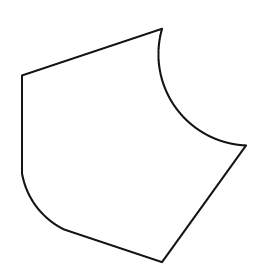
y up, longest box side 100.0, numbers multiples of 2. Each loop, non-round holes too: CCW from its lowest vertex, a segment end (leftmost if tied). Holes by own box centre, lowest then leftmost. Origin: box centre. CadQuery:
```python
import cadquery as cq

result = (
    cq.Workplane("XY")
    .moveTo(12.0, -50.0)
    .lineTo(48.0, 0.0)
    .threePointArc((18.0, 16.0), (12.0, 50.0))
    .lineTo(-48.0, 30.0)
    .lineTo(-48.0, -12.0)
    .threePointArc((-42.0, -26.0), (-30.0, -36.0))
    .close()
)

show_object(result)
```